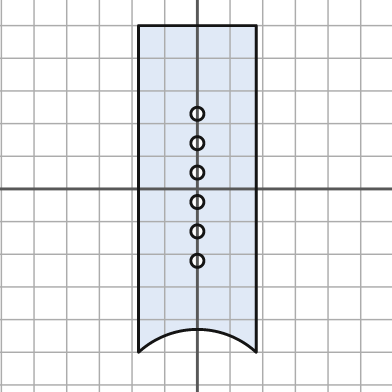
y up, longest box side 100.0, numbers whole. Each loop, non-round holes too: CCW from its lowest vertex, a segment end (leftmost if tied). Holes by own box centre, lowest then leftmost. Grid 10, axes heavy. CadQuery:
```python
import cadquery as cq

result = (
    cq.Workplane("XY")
    .moveTo(-18.0, -50.0)
    .threePointArc((0.0, -43.0), (18.0, -50.0))
    .lineTo(18.0, 50.0)
    .lineTo(-18.0, 50.0)
    .close()
    .moveTo(0.0, -22.0)
    .circle(2.0)
    .moveTo(0.0, -13.0)
    .circle(2.0)
    .moveTo(0.0, -4.0)
    .circle(2.0)
    .moveTo(0.0, 5.0)
    .circle(2.0)
    .moveTo(0.0, 14.0)
    .circle(2.0)
    .moveTo(0.0, 23.0)
    .circle(2.0)
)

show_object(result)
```